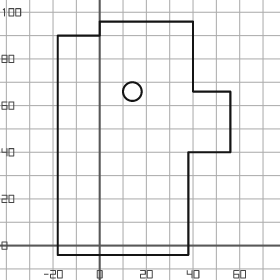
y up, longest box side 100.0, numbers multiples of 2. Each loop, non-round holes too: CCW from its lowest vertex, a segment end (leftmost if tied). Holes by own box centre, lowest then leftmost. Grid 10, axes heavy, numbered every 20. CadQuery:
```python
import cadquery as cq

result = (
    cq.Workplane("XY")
    .moveTo(-18.0, -4.0)
    .lineTo(38.0, -4.0)
    .lineTo(38.0, 40.0)
    .lineTo(56.0, 40.0)
    .lineTo(56.0, 66.0)
    .lineTo(40.0, 66.0)
    .lineTo(40.0, 96.0)
    .lineTo(0.0, 96.0)
    .lineTo(0.0, 90.0)
    .lineTo(-18.0, 90.0)
    .close()
    .moveTo(14.0, 66.0)
    .circle(4.0)
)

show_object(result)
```